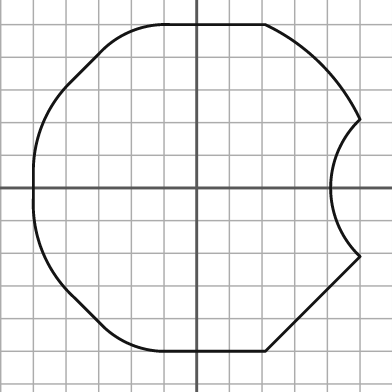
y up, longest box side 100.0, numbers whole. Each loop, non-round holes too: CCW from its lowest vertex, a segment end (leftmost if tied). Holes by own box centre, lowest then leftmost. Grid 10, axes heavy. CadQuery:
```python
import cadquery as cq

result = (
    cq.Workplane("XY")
    .moveTo(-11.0, -50.0)
    .lineTo(21.0, -50.0)
    .lineTo(50.0, -21.0)
    .threePointArc((41.0, 0.0), (50.0, 21.0))
    .threePointArc((38.0, 38.0), (21.0, 50.0))
    .lineTo(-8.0, 50.0)
    .threePointArc((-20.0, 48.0), (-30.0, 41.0))
    .lineTo(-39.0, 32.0)
    .threePointArc((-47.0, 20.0), (-50.0, 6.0))
    .lineTo(-50.0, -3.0)
    .threePointArc((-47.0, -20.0), (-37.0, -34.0))
    .lineTo(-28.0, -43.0)
    .threePointArc((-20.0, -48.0), (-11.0, -50.0))
    .close()
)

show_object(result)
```